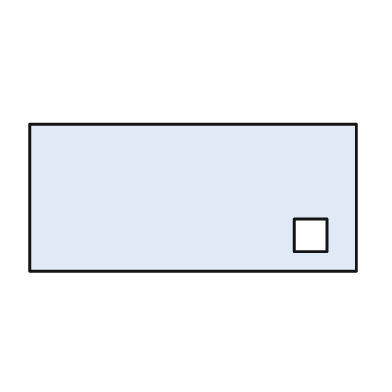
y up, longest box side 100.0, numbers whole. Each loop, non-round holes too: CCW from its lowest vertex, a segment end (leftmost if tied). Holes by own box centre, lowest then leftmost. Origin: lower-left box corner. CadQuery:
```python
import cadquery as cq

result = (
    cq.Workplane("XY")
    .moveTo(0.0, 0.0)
    .lineTo(100.0, 0.0)
    .lineTo(100.0, 45.0)
    .lineTo(0.0, 45.0)
    .close()
    .moveTo(81.0, 6.0)
    .lineTo(91.0, 6.0)
    .lineTo(91.0, 16.0)
    .lineTo(81.0, 16.0)
    .close()
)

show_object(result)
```